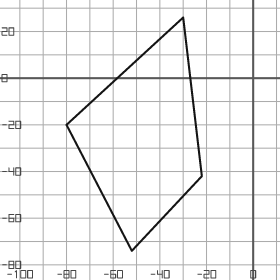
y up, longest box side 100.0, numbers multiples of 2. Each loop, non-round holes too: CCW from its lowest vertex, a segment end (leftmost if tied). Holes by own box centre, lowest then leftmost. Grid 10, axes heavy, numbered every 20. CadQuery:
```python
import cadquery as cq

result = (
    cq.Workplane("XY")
    .moveTo(-52.0, -74.0)
    .lineTo(-22.0, -42.0)
    .lineTo(-30.0, 26.0)
    .lineTo(-80.0, -20.0)
    .close()
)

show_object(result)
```